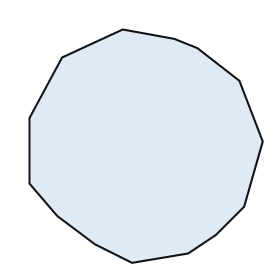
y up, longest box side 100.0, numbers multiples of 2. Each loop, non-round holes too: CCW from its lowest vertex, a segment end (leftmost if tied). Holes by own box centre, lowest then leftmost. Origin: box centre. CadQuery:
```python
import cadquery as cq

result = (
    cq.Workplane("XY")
    .moveTo(-6.0, -50.0)
    .lineTo(18.0, -46.0)
    .lineTo(30.0, -38.0)
    .lineTo(42.0, -26.0)
    .lineTo(50.0, 2.0)
    .lineTo(40.0, 28.0)
    .lineTo(22.0, 42.0)
    .lineTo(12.0, 46.0)
    .lineTo(-10.0, 50.0)
    .lineTo(-36.0, 38.0)
    .lineTo(-50.0, 12.0)
    .lineTo(-50.0, -16.0)
    .lineTo(-38.0, -30.0)
    .lineTo(-22.0, -42.0)
    .close()
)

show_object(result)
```